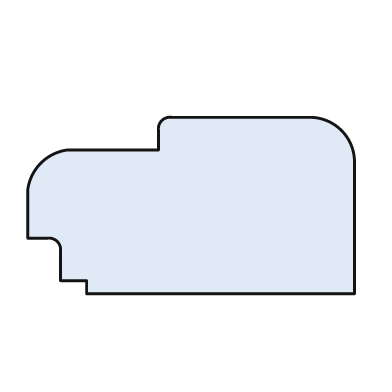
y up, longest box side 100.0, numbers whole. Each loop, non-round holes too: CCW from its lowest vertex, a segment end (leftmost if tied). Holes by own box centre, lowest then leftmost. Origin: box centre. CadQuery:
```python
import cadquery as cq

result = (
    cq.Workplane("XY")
    .moveTo(-32.0, -27.0)
    .lineTo(50.0, -27.0)
    .lineTo(50.0, 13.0)
    .threePointArc((46.0, 23.0), (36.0, 27.0))
    .lineTo(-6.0, 27.0)
    .threePointArc((-9.0, 26.0), (-10.0, 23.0))
    .lineTo(-10.0, 17.0)
    .lineTo(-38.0, 17.0)
    .threePointArc((-46.0, 13.0), (-50.0, 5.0))
    .lineTo(-50.0, -10.0)
    .lineTo(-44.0, -10.0)
    .threePointArc((-41.0, -11.0), (-40.0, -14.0))
    .lineTo(-40.0, -23.0)
    .lineTo(-32.0, -23.0)
    .close()
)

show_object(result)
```